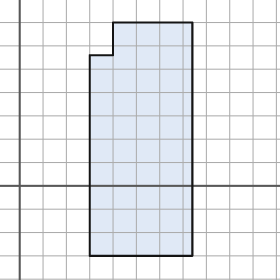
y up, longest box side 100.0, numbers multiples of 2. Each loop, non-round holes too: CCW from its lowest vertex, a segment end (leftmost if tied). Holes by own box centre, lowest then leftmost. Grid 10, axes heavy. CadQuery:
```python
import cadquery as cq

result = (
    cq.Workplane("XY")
    .moveTo(30.0, -30.0)
    .lineTo(74.0, -30.0)
    .lineTo(74.0, 70.0)
    .lineTo(40.0, 70.0)
    .lineTo(40.0, 56.0)
    .lineTo(30.0, 56.0)
    .close()
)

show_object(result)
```